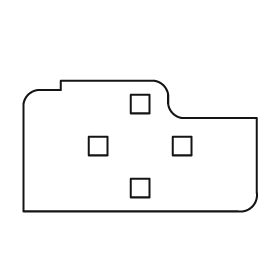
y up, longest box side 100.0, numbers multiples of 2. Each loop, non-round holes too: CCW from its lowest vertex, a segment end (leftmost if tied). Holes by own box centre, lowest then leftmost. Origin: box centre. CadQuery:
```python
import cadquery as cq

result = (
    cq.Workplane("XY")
    .moveTo(-50.0, -28.0)
    .lineTo(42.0, -28.0)
    .threePointArc((48.0, -26.0), (50.0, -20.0))
    .lineTo(50.0, 12.0)
    .lineTo(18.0, 12.0)
    .threePointArc((14.0, 14.0), (12.0, 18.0))
    .lineTo(12.0, 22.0)
    .threePointArc((10.0, 26.0), (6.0, 28.0))
    .lineTo(-34.0, 28.0)
    .lineTo(-34.0, 24.0)
    .lineTo(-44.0, 24.0)
    .threePointArc((-48.0, 22.0), (-50.0, 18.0))
    .close()
    .moveTo(-4.0, -22.0)
    .lineTo(4.0, -22.0)
    .lineTo(4.0, -14.0)
    .lineTo(-4.0, -14.0)
    .close()
    .moveTo(-22.0, -4.0)
    .lineTo(-14.0, -4.0)
    .lineTo(-14.0, 4.0)
    .lineTo(-22.0, 4.0)
    .close()
    .moveTo(14.0, -4.0)
    .lineTo(22.0, -4.0)
    .lineTo(22.0, 4.0)
    .lineTo(14.0, 4.0)
    .close()
    .moveTo(-4.0, 14.0)
    .lineTo(4.0, 14.0)
    .lineTo(4.0, 22.0)
    .lineTo(-4.0, 22.0)
    .close()
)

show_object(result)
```